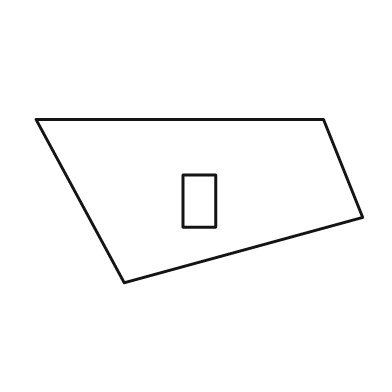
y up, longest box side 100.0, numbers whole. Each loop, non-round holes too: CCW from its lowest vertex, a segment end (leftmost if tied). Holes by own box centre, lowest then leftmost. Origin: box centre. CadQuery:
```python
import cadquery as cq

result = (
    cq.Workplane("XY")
    .moveTo(-23.0, -25.0)
    .lineTo(50.0, -5.0)
    .lineTo(38.0, 25.0)
    .lineTo(-50.0, 25.0)
    .close()
    .moveTo(-5.0, -8.0)
    .lineTo(5.0, -8.0)
    .lineTo(5.0, 8.0)
    .lineTo(-5.0, 8.0)
    .close()
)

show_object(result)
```